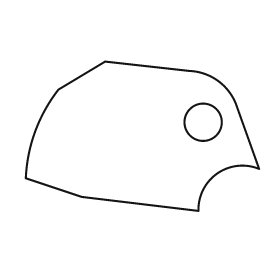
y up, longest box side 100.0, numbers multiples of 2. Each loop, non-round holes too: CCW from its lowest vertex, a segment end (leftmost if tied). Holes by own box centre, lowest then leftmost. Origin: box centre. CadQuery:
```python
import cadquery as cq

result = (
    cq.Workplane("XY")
    .moveTo(24.0, -32.0)
    .threePointArc((32.0, -16.0), (50.0, -14.0))
    .lineTo(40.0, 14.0)
    .threePointArc((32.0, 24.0), (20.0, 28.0))
    .lineTo(-16.0, 32.0)
    .lineTo(-36.0, 20.0)
    .threePointArc((-46.0, 2.0), (-50.0, -18.0))
    .lineTo(-26.0, -26.0)
    .close()
    .moveTo(26.0, 6.0)
    .circle(8.0)
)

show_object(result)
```